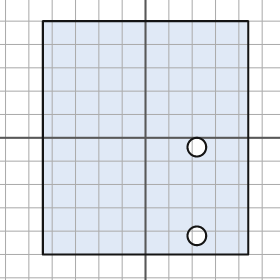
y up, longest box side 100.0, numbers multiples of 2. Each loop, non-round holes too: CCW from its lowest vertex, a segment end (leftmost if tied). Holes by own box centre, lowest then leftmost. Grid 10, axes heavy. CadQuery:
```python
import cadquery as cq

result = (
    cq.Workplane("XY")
    .moveTo(-44.0, -50.0)
    .lineTo(44.0, -50.0)
    .lineTo(44.0, 50.0)
    .lineTo(-44.0, 50.0)
    .close()
    .moveTo(22.0, -42.0)
    .circle(4.0)
    .moveTo(22.0, -4.0)
    .circle(4.0)
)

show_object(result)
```